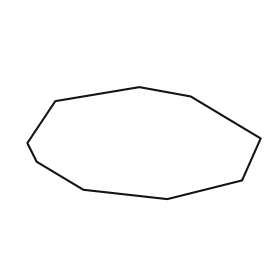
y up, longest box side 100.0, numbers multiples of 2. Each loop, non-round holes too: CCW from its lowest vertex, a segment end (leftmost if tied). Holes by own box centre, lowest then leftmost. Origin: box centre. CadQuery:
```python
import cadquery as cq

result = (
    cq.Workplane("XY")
    .moveTo(10.0, -24.0)
    .lineTo(42.0, -16.0)
    .lineTo(50.0, 2.0)
    .lineTo(20.0, 20.0)
    .lineTo(-2.0, 24.0)
    .lineTo(-38.0, 18.0)
    .lineTo(-50.0, 0.0)
    .lineTo(-46.0, -8.0)
    .lineTo(-26.0, -20.0)
    .close()
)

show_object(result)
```